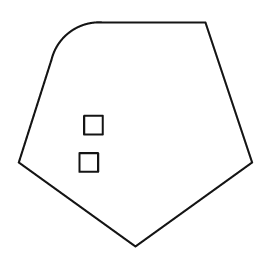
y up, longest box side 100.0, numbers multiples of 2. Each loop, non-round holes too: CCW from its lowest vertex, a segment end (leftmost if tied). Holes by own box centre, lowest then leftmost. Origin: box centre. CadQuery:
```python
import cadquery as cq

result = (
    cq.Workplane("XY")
    .moveTo(0.0, -48.0)
    .lineTo(50.0, -12.0)
    .lineTo(30.0, 48.0)
    .lineTo(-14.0, 48.0)
    .threePointArc((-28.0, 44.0), (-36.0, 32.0))
    .lineTo(-50.0, -12.0)
    .close()
    .moveTo(-24.0, -16.0)
    .lineTo(-16.0, -16.0)
    .lineTo(-16.0, -8.0)
    .lineTo(-24.0, -8.0)
    .close()
    .moveTo(-22.0, 0.0)
    .lineTo(-14.0, 0.0)
    .lineTo(-14.0, 8.0)
    .lineTo(-22.0, 8.0)
    .close()
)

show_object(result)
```